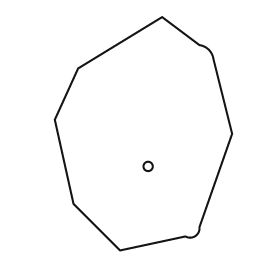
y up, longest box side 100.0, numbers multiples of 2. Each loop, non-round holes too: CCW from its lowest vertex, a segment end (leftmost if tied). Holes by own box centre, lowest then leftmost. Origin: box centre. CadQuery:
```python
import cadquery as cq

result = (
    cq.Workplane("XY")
    .moveTo(-10.0, -50.0)
    .lineTo(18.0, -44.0)
    .threePointArc((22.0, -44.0), (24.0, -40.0))
    .lineTo(38.0, 0.0)
    .lineTo(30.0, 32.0)
    .threePointArc((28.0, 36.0), (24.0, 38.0))
    .lineTo(8.0, 50.0)
    .lineTo(-28.0, 28.0)
    .lineTo(-38.0, 6.0)
    .lineTo(-30.0, -30.0)
    .close()
    .moveTo(2.0, -14.0)
    .circle(2.0)
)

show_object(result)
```